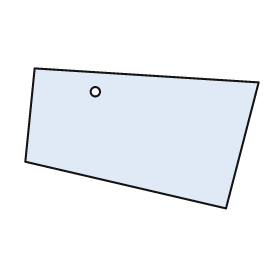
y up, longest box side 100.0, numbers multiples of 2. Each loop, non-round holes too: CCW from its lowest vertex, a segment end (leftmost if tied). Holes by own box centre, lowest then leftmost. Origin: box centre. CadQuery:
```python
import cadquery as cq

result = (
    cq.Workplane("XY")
    .moveTo(36.0, -30.0)
    .lineTo(50.0, 24.0)
    .lineTo(-46.0, 30.0)
    .lineTo(-50.0, -10.0)
    .close()
    .moveTo(-20.0, 20.0)
    .circle(2.0)
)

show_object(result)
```